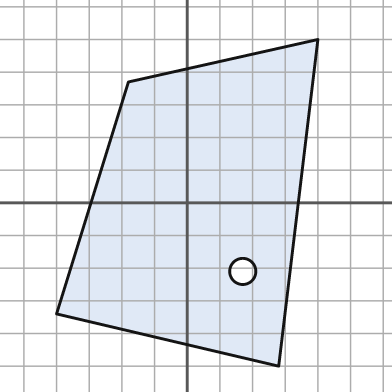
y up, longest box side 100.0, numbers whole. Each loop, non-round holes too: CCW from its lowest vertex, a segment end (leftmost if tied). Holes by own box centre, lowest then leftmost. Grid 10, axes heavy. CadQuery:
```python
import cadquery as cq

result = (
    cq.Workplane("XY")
    .moveTo(28.0, -50.0)
    .lineTo(40.0, 50.0)
    .lineTo(-18.0, 37.0)
    .lineTo(-40.0, -34.0)
    .close()
    .moveTo(17.0, -21.0)
    .circle(4.0)
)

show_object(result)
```